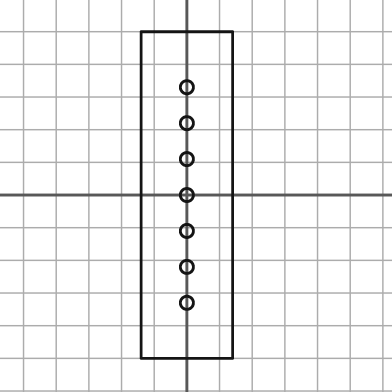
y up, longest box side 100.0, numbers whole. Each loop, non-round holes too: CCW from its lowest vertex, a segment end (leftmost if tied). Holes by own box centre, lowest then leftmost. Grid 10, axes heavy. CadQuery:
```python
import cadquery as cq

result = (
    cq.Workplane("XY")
    .moveTo(-14.0, -50.0)
    .lineTo(14.0, -50.0)
    .lineTo(14.0, 50.0)
    .lineTo(-14.0, 50.0)
    .close()
    .moveTo(0.0, -33.0)
    .circle(2.0)
    .moveTo(0.0, -22.0)
    .circle(2.0)
    .moveTo(0.0, -11.0)
    .circle(2.0)
    .moveTo(0.0, 0.0)
    .circle(2.0)
    .moveTo(0.0, 11.0)
    .circle(2.0)
    .moveTo(0.0, 22.0)
    .circle(2.0)
    .moveTo(0.0, 33.0)
    .circle(2.0)
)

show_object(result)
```